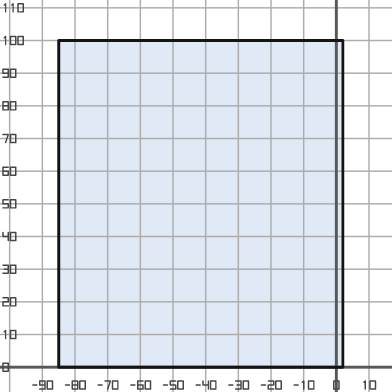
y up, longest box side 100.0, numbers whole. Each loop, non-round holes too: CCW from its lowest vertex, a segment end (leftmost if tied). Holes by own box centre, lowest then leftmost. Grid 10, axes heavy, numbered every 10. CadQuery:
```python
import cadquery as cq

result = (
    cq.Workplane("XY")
    .moveTo(-85.0, 0.0)
    .lineTo(2.0, 0.0)
    .lineTo(2.0, 100.0)
    .lineTo(-85.0, 100.0)
    .close()
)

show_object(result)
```